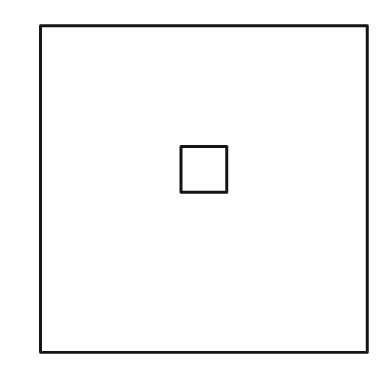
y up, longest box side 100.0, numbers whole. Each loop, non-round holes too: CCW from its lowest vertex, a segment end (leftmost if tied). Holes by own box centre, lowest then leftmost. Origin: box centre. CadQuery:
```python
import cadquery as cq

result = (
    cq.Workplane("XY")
    .moveTo(-50.0, -50.0)
    .lineTo(50.0, -50.0)
    .lineTo(50.0, 50.0)
    .lineTo(-50.0, 50.0)
    .close()
    .moveTo(-7.0, -1.0)
    .lineTo(7.0, -1.0)
    .lineTo(7.0, 13.0)
    .lineTo(-7.0, 13.0)
    .close()
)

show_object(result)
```